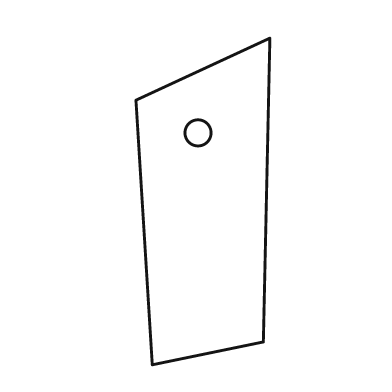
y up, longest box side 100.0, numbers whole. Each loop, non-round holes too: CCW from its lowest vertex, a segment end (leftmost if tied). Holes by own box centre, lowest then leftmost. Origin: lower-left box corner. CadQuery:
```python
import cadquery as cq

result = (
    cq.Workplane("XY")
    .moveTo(5.0, 0.0)
    .lineTo(39.0, 7.0)
    .lineTo(41.0, 100.0)
    .lineTo(0.0, 81.0)
    .close()
    .moveTo(19.0, 71.0)
    .circle(4.0)
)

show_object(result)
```